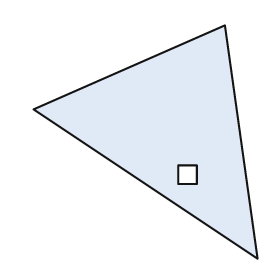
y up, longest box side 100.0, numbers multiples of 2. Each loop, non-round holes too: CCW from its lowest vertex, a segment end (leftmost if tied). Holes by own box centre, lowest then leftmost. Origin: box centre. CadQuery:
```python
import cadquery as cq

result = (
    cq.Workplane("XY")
    .moveTo(48.0, -50.0)
    .lineTo(34.0, 50.0)
    .lineTo(-48.0, 14.0)
    .close()
    .moveTo(14.0, -18.0)
    .lineTo(22.0, -18.0)
    .lineTo(22.0, -10.0)
    .lineTo(14.0, -10.0)
    .close()
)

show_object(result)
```